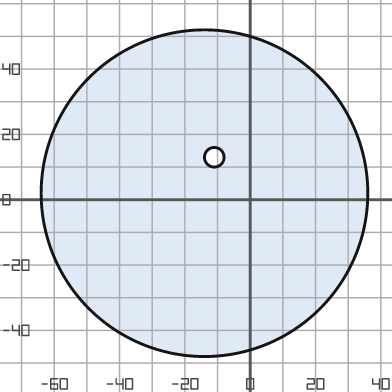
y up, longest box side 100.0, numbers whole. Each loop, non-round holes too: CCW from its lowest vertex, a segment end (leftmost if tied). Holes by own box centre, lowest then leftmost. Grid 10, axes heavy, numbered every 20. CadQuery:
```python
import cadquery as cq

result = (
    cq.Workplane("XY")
    .moveTo(-14.0, 2.0)
    .circle(50.0)
    .moveTo(-11.0, 13.0)
    .circle(3.0)
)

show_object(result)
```